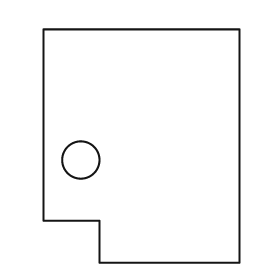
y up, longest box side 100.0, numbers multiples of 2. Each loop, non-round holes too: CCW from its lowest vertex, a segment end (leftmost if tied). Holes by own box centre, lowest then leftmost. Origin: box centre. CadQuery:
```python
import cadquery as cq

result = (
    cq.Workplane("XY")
    .moveTo(-18.0, -50.0)
    .lineTo(42.0, -50.0)
    .lineTo(42.0, 50.0)
    .lineTo(-42.0, 50.0)
    .lineTo(-42.0, -32.0)
    .lineTo(-18.0, -32.0)
    .close()
    .moveTo(-26.0, -6.0)
    .circle(8.0)
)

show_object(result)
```